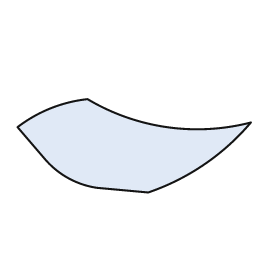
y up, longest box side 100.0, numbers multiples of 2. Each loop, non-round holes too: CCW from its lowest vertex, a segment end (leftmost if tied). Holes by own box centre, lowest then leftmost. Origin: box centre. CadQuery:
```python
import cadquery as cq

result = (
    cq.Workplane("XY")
    .moveTo(6.0, -20.0)
    .threePointArc((30.0, -8.0), (50.0, 10.0))
    .threePointArc((14.0, 8.0), (-20.0, 20.0))
    .threePointArc((-36.0, 16.0), (-50.0, 8.0))
    .lineTo(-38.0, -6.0)
    .threePointArc((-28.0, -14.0), (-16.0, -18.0))
    .close()
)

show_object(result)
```